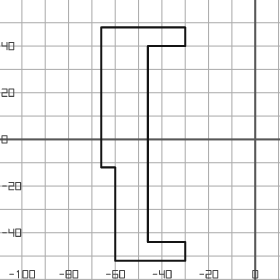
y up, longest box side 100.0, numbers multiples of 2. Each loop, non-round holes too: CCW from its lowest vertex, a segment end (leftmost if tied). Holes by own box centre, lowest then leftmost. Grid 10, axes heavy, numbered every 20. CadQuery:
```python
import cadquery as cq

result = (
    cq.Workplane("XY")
    .moveTo(-60.0, -52.0)
    .lineTo(-30.0, -52.0)
    .lineTo(-30.0, -44.0)
    .lineTo(-46.0, -44.0)
    .lineTo(-46.0, 40.0)
    .lineTo(-30.0, 40.0)
    .lineTo(-30.0, 48.0)
    .lineTo(-66.0, 48.0)
    .lineTo(-66.0, -12.0)
    .lineTo(-60.0, -12.0)
    .close()
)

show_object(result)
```